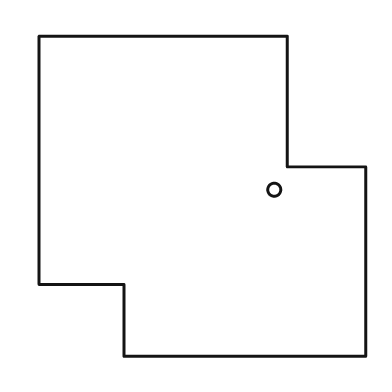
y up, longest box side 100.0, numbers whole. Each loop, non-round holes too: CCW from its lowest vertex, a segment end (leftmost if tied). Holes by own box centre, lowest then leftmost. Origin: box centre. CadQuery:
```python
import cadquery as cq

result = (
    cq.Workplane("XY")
    .moveTo(-24.0, -49.0)
    .lineTo(50.0, -49.0)
    .lineTo(50.0, 9.0)
    .lineTo(26.0, 9.0)
    .lineTo(26.0, 49.0)
    .lineTo(-50.0, 49.0)
    .lineTo(-50.0, -27.0)
    .lineTo(-24.0, -27.0)
    .close()
    .moveTo(22.0, 2.0)
    .circle(2.0)
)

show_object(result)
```